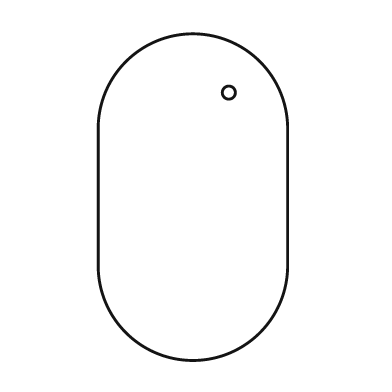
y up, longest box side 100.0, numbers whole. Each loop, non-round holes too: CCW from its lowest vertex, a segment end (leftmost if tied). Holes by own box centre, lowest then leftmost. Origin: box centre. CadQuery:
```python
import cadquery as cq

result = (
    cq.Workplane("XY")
    .moveTo(-29.0, -21.0)
    .threePointArc((0.0, -50.0), (29.0, -21.0))
    .lineTo(29.0, 21.0)
    .threePointArc((0.0, 50.0), (-29.0, 21.0))
    .close()
    .moveTo(11.0, 32.0)
    .circle(2.0)
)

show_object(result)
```